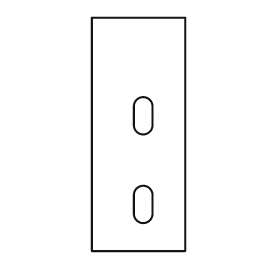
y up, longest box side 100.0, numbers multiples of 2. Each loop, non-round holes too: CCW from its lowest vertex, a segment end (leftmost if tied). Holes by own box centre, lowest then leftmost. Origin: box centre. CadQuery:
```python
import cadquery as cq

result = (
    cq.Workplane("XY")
    .moveTo(-20.0, -50.0)
    .lineTo(20.0, -50.0)
    .lineTo(20.0, 50.0)
    .lineTo(-20.0, 50.0)
    .close()
    .moveTo(-2.0, -34.0)
    .threePointArc((2.0, -38.0), (6.0, -34.0))
    .lineTo(6.0, -26.0)
    .threePointArc((2.0, -22.0), (-2.0, -26.0))
    .close()
    .moveTo(-2.0, 4.0)
    .threePointArc((2.0, 0.0), (6.0, 4.0))
    .lineTo(6.0, 12.0)
    .threePointArc((2.0, 16.0), (-2.0, 12.0))
    .close()
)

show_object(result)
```